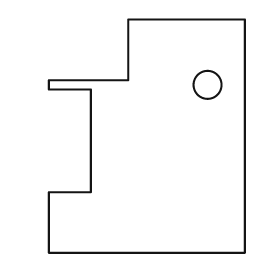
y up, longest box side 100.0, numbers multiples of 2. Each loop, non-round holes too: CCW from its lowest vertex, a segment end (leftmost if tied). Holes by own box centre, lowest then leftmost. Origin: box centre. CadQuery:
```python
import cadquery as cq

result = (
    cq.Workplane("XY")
    .moveTo(-42.0, -50.0)
    .lineTo(42.0, -50.0)
    .lineTo(42.0, 50.0)
    .lineTo(-8.0, 50.0)
    .lineTo(-8.0, 24.0)
    .lineTo(-42.0, 24.0)
    .lineTo(-42.0, 20.0)
    .lineTo(-24.0, 20.0)
    .lineTo(-24.0, -24.0)
    .lineTo(-42.0, -24.0)
    .close()
    .moveTo(26.0, 22.0)
    .circle(6.0)
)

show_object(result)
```